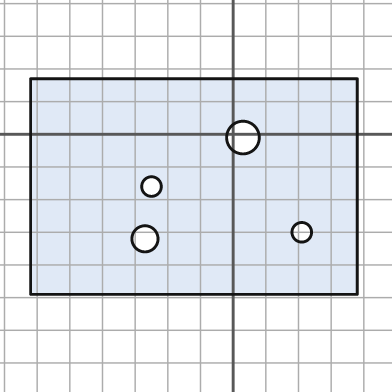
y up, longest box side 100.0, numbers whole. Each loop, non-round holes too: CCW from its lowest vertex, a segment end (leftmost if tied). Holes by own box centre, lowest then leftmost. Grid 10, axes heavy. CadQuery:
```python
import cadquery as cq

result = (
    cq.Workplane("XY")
    .moveTo(-62.0, -49.0)
    .lineTo(38.0, -49.0)
    .lineTo(38.0, 17.0)
    .lineTo(-62.0, 17.0)
    .close()
    .moveTo(-27.0, -32.0)
    .circle(4.0)
    .moveTo(21.0, -30.0)
    .circle(3.0)
    .moveTo(-25.0, -16.0)
    .circle(3.0)
    .moveTo(3.0, -1.0)
    .circle(5.0)
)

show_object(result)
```